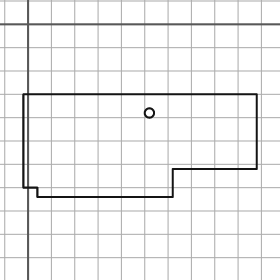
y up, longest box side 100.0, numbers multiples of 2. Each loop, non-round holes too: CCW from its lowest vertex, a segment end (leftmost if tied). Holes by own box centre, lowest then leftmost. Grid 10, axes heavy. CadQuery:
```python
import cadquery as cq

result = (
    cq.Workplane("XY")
    .moveTo(4.0, -74.0)
    .lineTo(62.0, -74.0)
    .lineTo(62.0, -62.0)
    .lineTo(98.0, -62.0)
    .lineTo(98.0, -30.0)
    .lineTo(-2.0, -30.0)
    .lineTo(-2.0, -70.0)
    .lineTo(4.0, -70.0)
    .close()
    .moveTo(52.0, -38.0)
    .circle(2.0)
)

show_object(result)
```